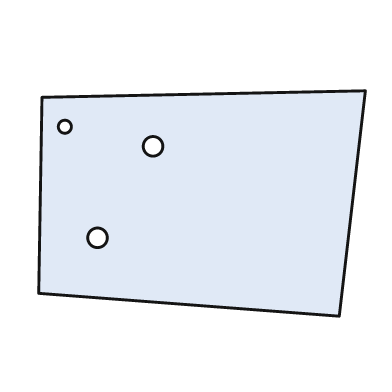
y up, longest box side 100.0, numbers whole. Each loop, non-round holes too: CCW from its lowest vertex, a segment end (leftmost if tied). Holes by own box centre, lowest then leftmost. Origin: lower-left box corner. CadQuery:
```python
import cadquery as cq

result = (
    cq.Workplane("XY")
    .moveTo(92.0, 0.0)
    .lineTo(100.0, 69.0)
    .lineTo(1.0, 67.0)
    .lineTo(0.0, 7.0)
    .close()
    .moveTo(18.0, 24.0)
    .circle(3.0)
    .moveTo(35.0, 52.0)
    .circle(3.0)
    .moveTo(8.0, 58.0)
    .circle(2.0)
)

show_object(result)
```